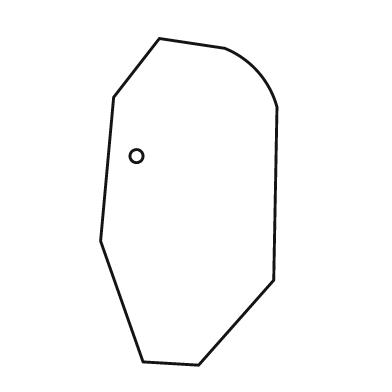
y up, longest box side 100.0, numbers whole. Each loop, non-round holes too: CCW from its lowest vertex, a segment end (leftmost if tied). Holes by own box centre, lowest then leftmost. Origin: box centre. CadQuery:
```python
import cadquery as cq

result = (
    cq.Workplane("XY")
    .moveTo(3.0, -50.0)
    .lineTo(26.0, -24.0)
    .lineTo(27.0, 29.0)
    .threePointArc((21.0, 40.0), (11.0, 47.0))
    .lineTo(-9.0, 50.0)
    .lineTo(-23.0, 32.0)
    .lineTo(-27.0, -12.0)
    .lineTo(-14.0, -49.0)
    .close()
    .moveTo(-16.0, 14.0)
    .circle(2.0)
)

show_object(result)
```